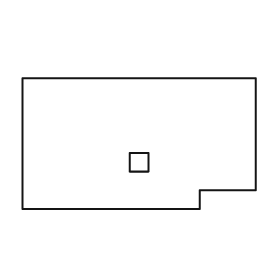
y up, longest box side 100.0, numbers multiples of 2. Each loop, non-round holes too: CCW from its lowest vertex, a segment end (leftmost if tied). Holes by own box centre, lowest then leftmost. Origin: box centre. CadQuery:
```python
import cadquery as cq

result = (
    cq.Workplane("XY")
    .moveTo(-50.0, -28.0)
    .lineTo(26.0, -28.0)
    .lineTo(26.0, -20.0)
    .lineTo(50.0, -20.0)
    .lineTo(50.0, 28.0)
    .lineTo(-50.0, 28.0)
    .close()
    .moveTo(-4.0, -12.0)
    .lineTo(4.0, -12.0)
    .lineTo(4.0, -4.0)
    .lineTo(-4.0, -4.0)
    .close()
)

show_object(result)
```